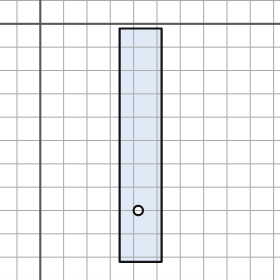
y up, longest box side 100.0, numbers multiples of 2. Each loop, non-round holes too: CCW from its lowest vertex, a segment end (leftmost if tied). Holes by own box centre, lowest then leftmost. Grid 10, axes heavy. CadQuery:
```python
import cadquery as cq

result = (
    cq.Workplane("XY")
    .moveTo(34.0, -102.0)
    .lineTo(52.0, -102.0)
    .lineTo(52.0, -2.0)
    .lineTo(34.0, -2.0)
    .close()
    .moveTo(42.0, -80.0)
    .circle(2.0)
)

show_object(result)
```